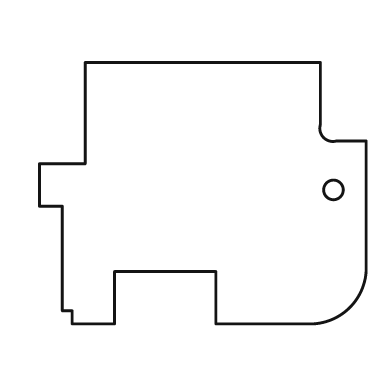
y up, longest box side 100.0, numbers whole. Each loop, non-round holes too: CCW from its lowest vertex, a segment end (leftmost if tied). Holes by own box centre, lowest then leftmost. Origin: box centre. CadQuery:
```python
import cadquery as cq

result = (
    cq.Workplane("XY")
    .moveTo(-40.0, -40.0)
    .lineTo(-27.0, -40.0)
    .lineTo(-27.0, -24.0)
    .lineTo(4.0, -24.0)
    .lineTo(4.0, -40.0)
    .lineTo(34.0, -40.0)
    .threePointArc((45.0, -35.0), (50.0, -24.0))
    .lineTo(50.0, 16.0)
    .lineTo(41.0, 16.0)
    .threePointArc((37.0, 17.0), (36.0, 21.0))
    .lineTo(36.0, 40.0)
    .lineTo(-36.0, 40.0)
    .lineTo(-36.0, 9.0)
    .lineTo(-50.0, 9.0)
    .lineTo(-50.0, -4.0)
    .lineTo(-43.0, -4.0)
    .lineTo(-43.0, -36.0)
    .lineTo(-40.0, -36.0)
    .close()
    .moveTo(40.0, 1.0)
    .circle(3.0)
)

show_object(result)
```